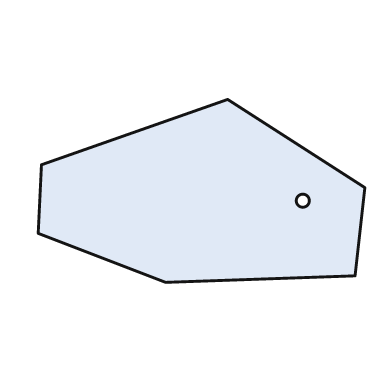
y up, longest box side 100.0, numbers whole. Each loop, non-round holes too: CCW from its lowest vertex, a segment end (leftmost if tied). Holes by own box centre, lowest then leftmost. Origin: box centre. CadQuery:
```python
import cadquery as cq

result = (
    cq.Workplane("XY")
    .moveTo(-11.0, -28.0)
    .lineTo(47.0, -26.0)
    .lineTo(50.0, 1.0)
    .lineTo(8.0, 28.0)
    .lineTo(-49.0, 8.0)
    .lineTo(-50.0, -13.0)
    .close()
    .moveTo(31.0, -3.0)
    .circle(2.0)
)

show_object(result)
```